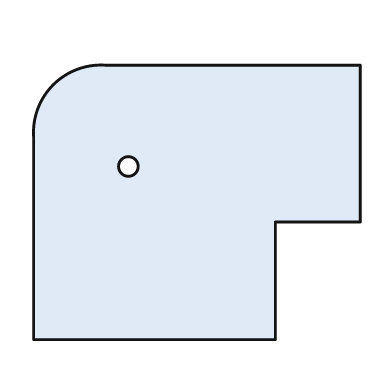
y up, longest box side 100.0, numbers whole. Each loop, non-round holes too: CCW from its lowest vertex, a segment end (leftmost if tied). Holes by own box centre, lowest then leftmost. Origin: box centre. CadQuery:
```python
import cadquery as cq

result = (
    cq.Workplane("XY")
    .moveTo(-50.0, -42.0)
    .lineTo(24.0, -42.0)
    .lineTo(24.0, -6.0)
    .lineTo(50.0, -6.0)
    .lineTo(50.0, 42.0)
    .lineTo(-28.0, 42.0)
    .threePointArc((-44.0, 36.0), (-50.0, 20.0))
    .close()
    .moveTo(-21.0, 11.0)
    .circle(3.0)
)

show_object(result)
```